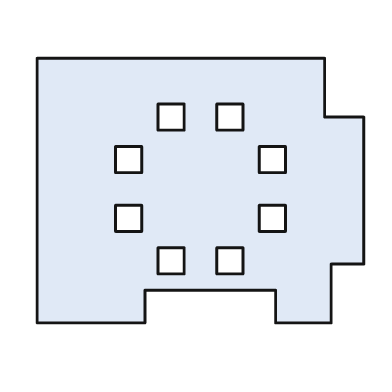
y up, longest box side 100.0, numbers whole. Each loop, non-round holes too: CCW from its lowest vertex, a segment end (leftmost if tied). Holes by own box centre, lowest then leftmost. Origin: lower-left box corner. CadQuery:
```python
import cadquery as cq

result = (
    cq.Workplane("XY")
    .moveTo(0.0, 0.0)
    .lineTo(33.0, 0.0)
    .lineTo(33.0, 10.0)
    .lineTo(73.0, 10.0)
    .lineTo(73.0, 0.0)
    .lineTo(90.0, 0.0)
    .lineTo(90.0, 18.0)
    .lineTo(100.0, 18.0)
    .lineTo(100.0, 63.0)
    .lineTo(88.0, 63.0)
    .lineTo(88.0, 81.0)
    .lineTo(0.0, 81.0)
    .close()
    .moveTo(37.0, 15.0)
    .lineTo(45.0, 15.0)
    .lineTo(45.0, 23.0)
    .lineTo(37.0, 23.0)
    .close()
    .moveTo(55.0, 15.0)
    .lineTo(63.0, 15.0)
    .lineTo(63.0, 23.0)
    .lineTo(55.0, 23.0)
    .close()
    .moveTo(24.0, 28.0)
    .lineTo(32.0, 28.0)
    .lineTo(32.0, 36.0)
    .lineTo(24.0, 36.0)
    .close()
    .moveTo(68.0, 28.0)
    .lineTo(76.0, 28.0)
    .lineTo(76.0, 36.0)
    .lineTo(68.0, 36.0)
    .close()
    .moveTo(24.0, 46.0)
    .lineTo(32.0, 46.0)
    .lineTo(32.0, 54.0)
    .lineTo(24.0, 54.0)
    .close()
    .moveTo(68.0, 46.0)
    .lineTo(76.0, 46.0)
    .lineTo(76.0, 54.0)
    .lineTo(68.0, 54.0)
    .close()
    .moveTo(37.0, 59.0)
    .lineTo(45.0, 59.0)
    .lineTo(45.0, 67.0)
    .lineTo(37.0, 67.0)
    .close()
    .moveTo(55.0, 59.0)
    .lineTo(63.0, 59.0)
    .lineTo(63.0, 67.0)
    .lineTo(55.0, 67.0)
    .close()
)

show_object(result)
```